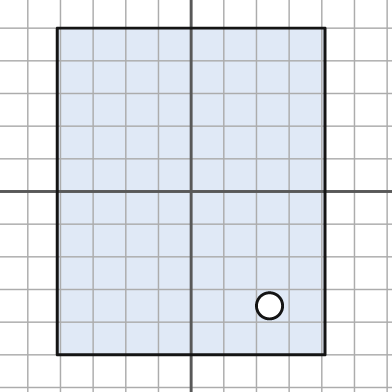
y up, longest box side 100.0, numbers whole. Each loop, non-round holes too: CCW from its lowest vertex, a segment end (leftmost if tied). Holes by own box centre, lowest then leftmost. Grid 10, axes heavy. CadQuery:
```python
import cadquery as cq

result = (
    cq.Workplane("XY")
    .moveTo(-41.0, -50.0)
    .lineTo(41.0, -50.0)
    .lineTo(41.0, 50.0)
    .lineTo(-41.0, 50.0)
    .close()
    .moveTo(24.0, -35.0)
    .circle(4.0)
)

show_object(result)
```